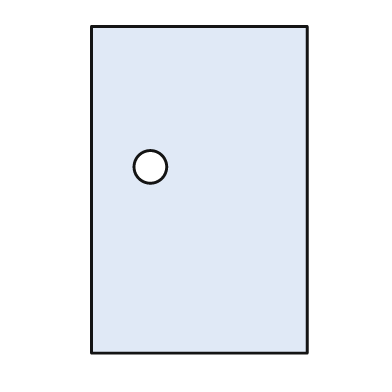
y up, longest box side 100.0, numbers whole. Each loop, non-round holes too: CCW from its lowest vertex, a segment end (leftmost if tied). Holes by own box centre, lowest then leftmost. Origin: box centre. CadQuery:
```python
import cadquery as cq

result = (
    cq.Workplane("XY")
    .moveTo(-33.0, -50.0)
    .lineTo(33.0, -50.0)
    .lineTo(33.0, 50.0)
    .lineTo(-33.0, 50.0)
    .close()
    .moveTo(-15.0, 7.0)
    .circle(5.0)
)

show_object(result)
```